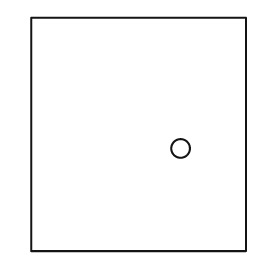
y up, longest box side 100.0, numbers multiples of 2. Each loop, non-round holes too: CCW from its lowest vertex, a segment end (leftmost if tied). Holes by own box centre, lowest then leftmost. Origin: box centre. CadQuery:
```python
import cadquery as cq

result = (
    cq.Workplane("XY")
    .moveTo(-46.0, -50.0)
    .lineTo(46.0, -50.0)
    .lineTo(46.0, 50.0)
    .lineTo(-46.0, 50.0)
    .close()
    .moveTo(18.0, -6.0)
    .circle(4.0)
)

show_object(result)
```